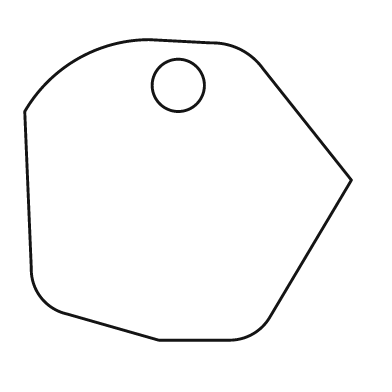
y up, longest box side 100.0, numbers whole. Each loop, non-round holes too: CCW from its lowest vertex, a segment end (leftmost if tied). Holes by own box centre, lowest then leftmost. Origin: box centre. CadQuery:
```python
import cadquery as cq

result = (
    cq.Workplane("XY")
    .moveTo(-9.0, -46.0)
    .lineTo(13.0, -46.0)
    .threePointArc((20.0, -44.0), (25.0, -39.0))
    .lineTo(50.0, 3.0)
    .lineTo(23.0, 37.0)
    .threePointArc((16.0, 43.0), (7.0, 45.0))
    .lineTo(-12.0, 46.0)
    .threePointArc((-34.0, 40.0), (-50.0, 24.0))
    .lineTo(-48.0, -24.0)
    .threePointArc((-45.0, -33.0), (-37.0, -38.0))
    .close()
    .moveTo(-3.0, 32.0)
    .circle(8.0)
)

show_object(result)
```